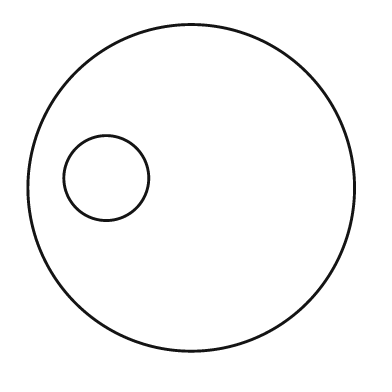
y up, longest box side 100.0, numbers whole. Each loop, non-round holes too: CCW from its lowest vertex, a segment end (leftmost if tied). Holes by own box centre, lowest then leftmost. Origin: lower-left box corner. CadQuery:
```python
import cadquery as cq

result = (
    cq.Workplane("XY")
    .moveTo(50.0, 50.0)
    .circle(50.0)
    .moveTo(24.0, 53.0)
    .circle(13.0)
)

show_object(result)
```